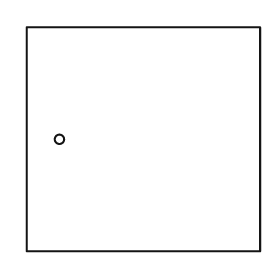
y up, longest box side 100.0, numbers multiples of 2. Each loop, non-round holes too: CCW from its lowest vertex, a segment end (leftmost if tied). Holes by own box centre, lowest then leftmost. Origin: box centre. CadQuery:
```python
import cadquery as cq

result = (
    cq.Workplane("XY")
    .moveTo(-50.0, -48.0)
    .lineTo(50.0, -48.0)
    .lineTo(50.0, 48.0)
    .lineTo(-50.0, 48.0)
    .close()
    .moveTo(-36.0, 0.0)
    .circle(2.0)
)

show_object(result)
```